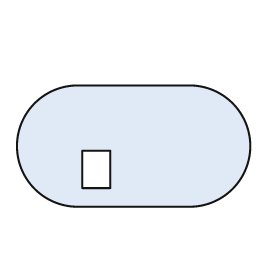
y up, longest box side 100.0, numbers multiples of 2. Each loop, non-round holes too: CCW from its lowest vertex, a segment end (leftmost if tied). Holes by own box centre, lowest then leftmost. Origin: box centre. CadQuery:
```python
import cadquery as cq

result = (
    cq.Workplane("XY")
    .moveTo(-24.0, -26.0)
    .lineTo(24.0, -26.0)
    .threePointArc((50.0, 0.0), (24.0, 26.0))
    .lineTo(-24.0, 26.0)
    .threePointArc((-50.0, 0.0), (-24.0, -26.0))
    .close()
    .moveTo(-22.0, -18.0)
    .lineTo(-10.0, -18.0)
    .lineTo(-10.0, -2.0)
    .lineTo(-22.0, -2.0)
    .close()
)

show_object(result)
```